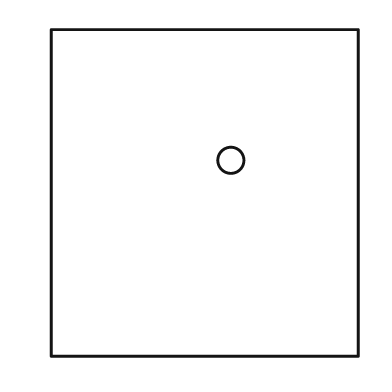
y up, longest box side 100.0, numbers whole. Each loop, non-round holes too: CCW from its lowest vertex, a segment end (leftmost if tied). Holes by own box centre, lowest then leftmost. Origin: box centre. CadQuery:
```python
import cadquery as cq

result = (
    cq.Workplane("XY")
    .moveTo(-47.0, -50.0)
    .lineTo(47.0, -50.0)
    .lineTo(47.0, 50.0)
    .lineTo(-47.0, 50.0)
    .close()
    .moveTo(8.0, 10.0)
    .circle(4.0)
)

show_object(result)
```